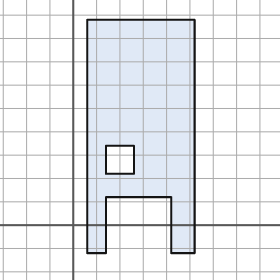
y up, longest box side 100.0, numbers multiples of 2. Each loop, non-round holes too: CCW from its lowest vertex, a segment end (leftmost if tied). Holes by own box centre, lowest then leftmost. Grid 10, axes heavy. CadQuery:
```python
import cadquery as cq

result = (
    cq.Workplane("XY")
    .moveTo(6.0, -12.0)
    .lineTo(14.0, -12.0)
    .lineTo(14.0, 12.0)
    .lineTo(42.0, 12.0)
    .lineTo(42.0, -12.0)
    .lineTo(52.0, -12.0)
    .lineTo(52.0, 88.0)
    .lineTo(6.0, 88.0)
    .close()
    .moveTo(14.0, 22.0)
    .lineTo(26.0, 22.0)
    .lineTo(26.0, 34.0)
    .lineTo(14.0, 34.0)
    .close()
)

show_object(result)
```